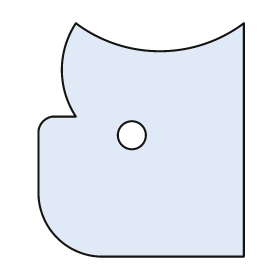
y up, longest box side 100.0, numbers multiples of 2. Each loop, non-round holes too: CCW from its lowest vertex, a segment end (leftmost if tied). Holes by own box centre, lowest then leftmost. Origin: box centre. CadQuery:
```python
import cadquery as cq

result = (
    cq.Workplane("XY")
    .moveTo(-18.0, -50.0)
    .lineTo(44.0, -50.0)
    .lineTo(44.0, 50.0)
    .threePointArc((8.0, 38.0), (-28.0, 50.0))
    .threePointArc((-34.0, 30.0), (-28.0, 10.0))
    .lineTo(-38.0, 10.0)
    .threePointArc((-42.0, 8.0), (-44.0, 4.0))
    .lineTo(-44.0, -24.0)
    .threePointArc((-36.0, -42.0), (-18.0, -50.0))
    .close()
    .moveTo(-4.0, 2.0)
    .circle(6.0)
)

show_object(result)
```